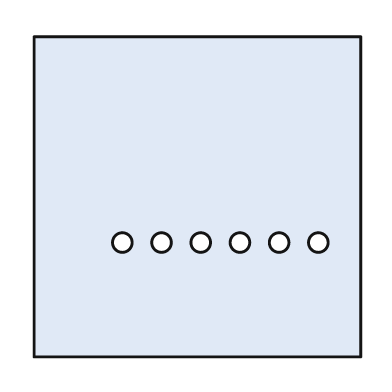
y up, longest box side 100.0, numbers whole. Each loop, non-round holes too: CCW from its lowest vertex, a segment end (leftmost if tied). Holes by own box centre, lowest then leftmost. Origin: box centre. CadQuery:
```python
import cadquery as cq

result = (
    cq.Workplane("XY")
    .moveTo(-50.0, -49.0)
    .lineTo(50.0, -49.0)
    .lineTo(50.0, 49.0)
    .lineTo(-50.0, 49.0)
    .close()
    .moveTo(-23.0, -14.0)
    .circle(3.0)
    .moveTo(-11.0, -14.0)
    .circle(3.0)
    .moveTo(1.0, -14.0)
    .circle(3.0)
    .moveTo(13.0, -14.0)
    .circle(3.0)
    .moveTo(25.0, -14.0)
    .circle(3.0)
    .moveTo(37.0, -14.0)
    .circle(3.0)
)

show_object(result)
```